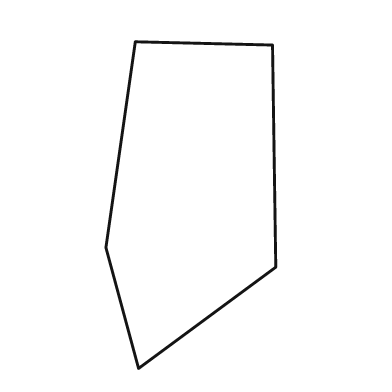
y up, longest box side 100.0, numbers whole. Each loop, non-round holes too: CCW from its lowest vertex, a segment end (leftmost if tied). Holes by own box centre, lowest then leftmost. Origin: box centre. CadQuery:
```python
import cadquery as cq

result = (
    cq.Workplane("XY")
    .moveTo(-16.0, -50.0)
    .lineTo(26.0, -19.0)
    .lineTo(25.0, 49.0)
    .lineTo(-17.0, 50.0)
    .lineTo(-26.0, -13.0)
    .close()
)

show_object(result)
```